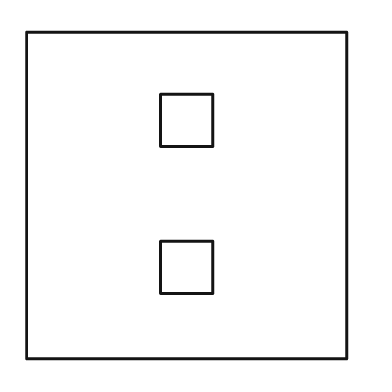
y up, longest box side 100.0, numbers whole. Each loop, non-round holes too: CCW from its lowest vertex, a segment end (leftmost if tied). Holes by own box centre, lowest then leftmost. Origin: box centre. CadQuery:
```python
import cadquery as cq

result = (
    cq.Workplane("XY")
    .moveTo(-49.0, -50.0)
    .lineTo(49.0, -50.0)
    .lineTo(49.0, 50.0)
    .lineTo(-49.0, 50.0)
    .close()
    .moveTo(-8.0, -30.0)
    .lineTo(8.0, -30.0)
    .lineTo(8.0, -14.0)
    .lineTo(-8.0, -14.0)
    .close()
    .moveTo(-8.0, 15.0)
    .lineTo(8.0, 15.0)
    .lineTo(8.0, 31.0)
    .lineTo(-8.0, 31.0)
    .close()
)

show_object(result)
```